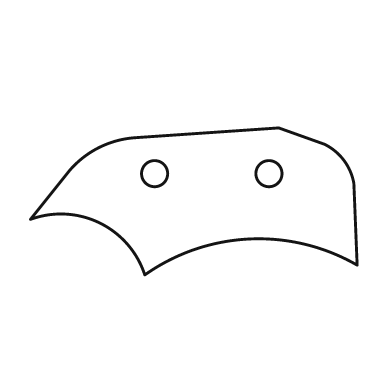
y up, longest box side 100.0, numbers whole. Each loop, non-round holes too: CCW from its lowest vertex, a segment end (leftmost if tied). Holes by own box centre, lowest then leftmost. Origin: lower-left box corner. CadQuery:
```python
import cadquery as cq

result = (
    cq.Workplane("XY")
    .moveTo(35.0, 0.0)
    .threePointArc((67.0, 11.0), (100.0, 3.0))
    .lineTo(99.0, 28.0)
    .threePointArc((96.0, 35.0), (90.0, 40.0))
    .lineTo(76.0, 45.0)
    .lineTo(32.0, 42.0)
    .threePointArc((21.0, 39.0), (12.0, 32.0))
    .lineTo(0.0, 17.0)
    .threePointArc((21.0, 16.0), (35.0, 0.0))
    .close()
    .moveTo(38.0, 31.0)
    .circle(4.0)
    .moveTo(73.0, 31.0)
    .circle(4.0)
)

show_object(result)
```